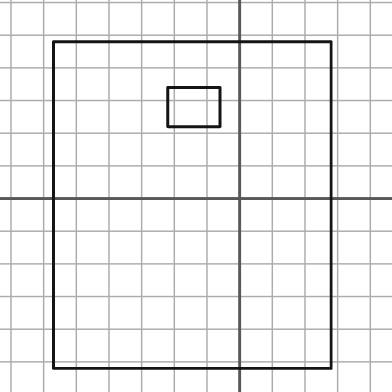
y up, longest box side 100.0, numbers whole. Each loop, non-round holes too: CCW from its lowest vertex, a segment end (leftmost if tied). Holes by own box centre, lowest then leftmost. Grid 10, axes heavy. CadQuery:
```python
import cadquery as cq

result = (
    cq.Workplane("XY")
    .moveTo(-57.0, -52.0)
    .lineTo(28.0, -52.0)
    .lineTo(28.0, 48.0)
    .lineTo(-57.0, 48.0)
    .close()
    .moveTo(-22.0, 22.0)
    .lineTo(-6.0, 22.0)
    .lineTo(-6.0, 34.0)
    .lineTo(-22.0, 34.0)
    .close()
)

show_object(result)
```